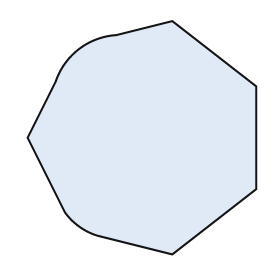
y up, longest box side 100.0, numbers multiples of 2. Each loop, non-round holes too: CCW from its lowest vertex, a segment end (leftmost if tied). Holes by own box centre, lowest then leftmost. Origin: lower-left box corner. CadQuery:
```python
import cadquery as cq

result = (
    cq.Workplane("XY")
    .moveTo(62.0, 0.0)
    .lineTo(98.0, 28.0)
    .lineTo(98.0, 72.0)
    .lineTo(62.0, 100.0)
    .lineTo(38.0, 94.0)
    .threePointArc((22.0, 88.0), (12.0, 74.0))
    .lineTo(0.0, 50.0)
    .lineTo(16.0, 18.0)
    .threePointArc((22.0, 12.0), (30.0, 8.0))
    .close()
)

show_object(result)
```